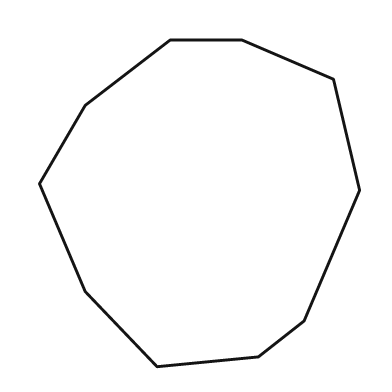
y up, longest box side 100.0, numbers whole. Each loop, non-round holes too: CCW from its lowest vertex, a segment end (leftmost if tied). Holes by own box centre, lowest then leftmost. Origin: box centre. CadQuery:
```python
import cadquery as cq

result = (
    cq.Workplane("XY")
    .moveTo(-13.0, -50.0)
    .lineTo(18.0, -47.0)
    .lineTo(32.0, -36.0)
    .lineTo(49.0, 4.0)
    .lineTo(41.0, 38.0)
    .lineTo(13.0, 50.0)
    .lineTo(-9.0, 50.0)
    .lineTo(-35.0, 30.0)
    .lineTo(-49.0, 6.0)
    .lineTo(-35.0, -27.0)
    .close()
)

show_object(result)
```